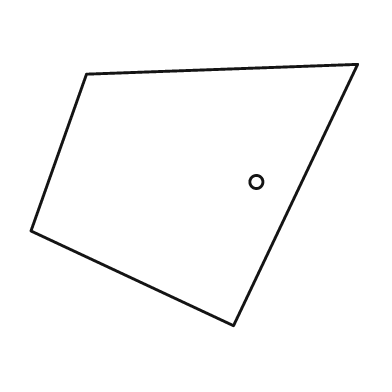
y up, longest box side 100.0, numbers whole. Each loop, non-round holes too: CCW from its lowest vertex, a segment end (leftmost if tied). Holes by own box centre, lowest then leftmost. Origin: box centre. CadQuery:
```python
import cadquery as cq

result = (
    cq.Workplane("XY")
    .moveTo(12.0, -40.0)
    .lineTo(50.0, 40.0)
    .lineTo(-33.0, 37.0)
    .lineTo(-50.0, -11.0)
    .close()
    .moveTo(19.0, 4.0)
    .circle(2.0)
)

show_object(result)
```